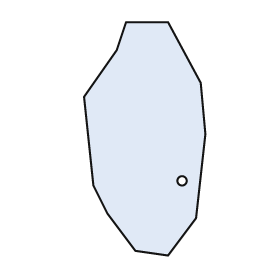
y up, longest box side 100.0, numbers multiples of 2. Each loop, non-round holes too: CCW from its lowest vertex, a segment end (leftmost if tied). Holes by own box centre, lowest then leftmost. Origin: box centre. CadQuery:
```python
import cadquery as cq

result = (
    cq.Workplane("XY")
    .moveTo(10.0, -50.0)
    .lineTo(22.0, -34.0)
    .lineTo(26.0, 2.0)
    .lineTo(24.0, 24.0)
    .lineTo(10.0, 50.0)
    .lineTo(-8.0, 50.0)
    .lineTo(-12.0, 38.0)
    .lineTo(-26.0, 18.0)
    .lineTo(-22.0, -20.0)
    .lineTo(-16.0, -32.0)
    .lineTo(-4.0, -48.0)
    .close()
    .moveTo(16.0, -18.0)
    .circle(2.0)
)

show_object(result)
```